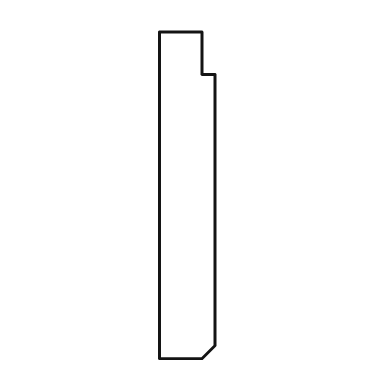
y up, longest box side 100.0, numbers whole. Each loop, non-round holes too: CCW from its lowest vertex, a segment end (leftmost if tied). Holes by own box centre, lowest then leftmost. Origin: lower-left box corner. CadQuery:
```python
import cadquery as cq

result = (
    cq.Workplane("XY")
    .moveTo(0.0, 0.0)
    .lineTo(13.0, 0.0)
    .lineTo(17.0, 4.0)
    .lineTo(17.0, 87.0)
    .lineTo(13.0, 87.0)
    .lineTo(13.0, 100.0)
    .lineTo(0.0, 100.0)
    .close()
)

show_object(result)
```